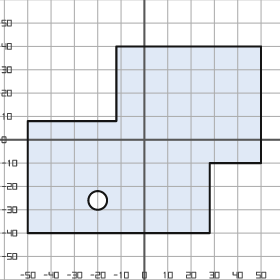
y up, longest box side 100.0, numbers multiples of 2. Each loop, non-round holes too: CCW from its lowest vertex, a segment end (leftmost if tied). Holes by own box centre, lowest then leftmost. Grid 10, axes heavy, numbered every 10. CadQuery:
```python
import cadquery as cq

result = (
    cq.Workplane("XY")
    .moveTo(-50.0, -40.0)
    .lineTo(28.0, -40.0)
    .lineTo(28.0, -10.0)
    .lineTo(50.0, -10.0)
    .lineTo(50.0, 40.0)
    .lineTo(-12.0, 40.0)
    .lineTo(-12.0, 8.0)
    .lineTo(-50.0, 8.0)
    .close()
    .moveTo(-20.0, -26.0)
    .circle(4.0)
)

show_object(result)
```